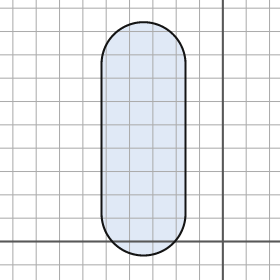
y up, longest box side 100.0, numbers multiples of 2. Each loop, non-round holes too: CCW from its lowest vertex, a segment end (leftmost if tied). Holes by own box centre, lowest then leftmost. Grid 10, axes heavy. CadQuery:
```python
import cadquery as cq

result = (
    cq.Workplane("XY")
    .moveTo(-52.0, 12.0)
    .threePointArc((-34.0, -6.0), (-16.0, 12.0))
    .lineTo(-16.0, 76.0)
    .threePointArc((-34.0, 94.0), (-52.0, 76.0))
    .close()
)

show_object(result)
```